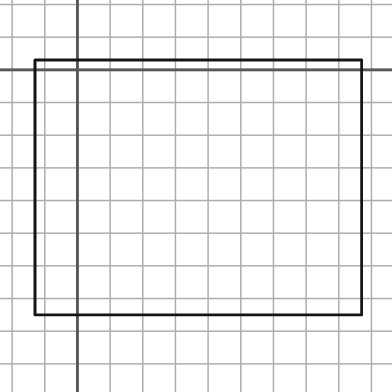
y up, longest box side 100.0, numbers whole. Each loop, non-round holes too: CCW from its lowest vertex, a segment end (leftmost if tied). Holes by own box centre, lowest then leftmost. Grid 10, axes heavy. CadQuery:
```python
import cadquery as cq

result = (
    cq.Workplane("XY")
    .moveTo(-13.0, -75.0)
    .lineTo(87.0, -75.0)
    .lineTo(87.0, 3.0)
    .lineTo(-13.0, 3.0)
    .close()
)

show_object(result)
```